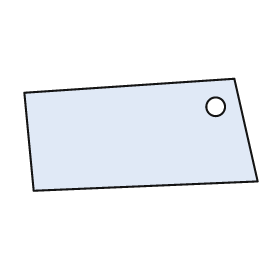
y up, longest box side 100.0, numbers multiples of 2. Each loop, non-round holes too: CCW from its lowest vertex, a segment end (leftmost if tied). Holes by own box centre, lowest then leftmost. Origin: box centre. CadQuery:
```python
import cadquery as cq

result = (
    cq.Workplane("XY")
    .moveTo(-46.0, -24.0)
    .lineTo(50.0, -20.0)
    .lineTo(40.0, 24.0)
    .lineTo(-50.0, 18.0)
    .close()
    .moveTo(32.0, 12.0)
    .circle(4.0)
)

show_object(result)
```